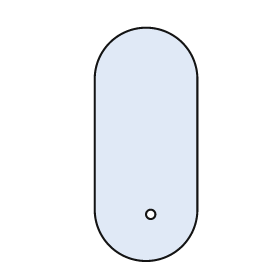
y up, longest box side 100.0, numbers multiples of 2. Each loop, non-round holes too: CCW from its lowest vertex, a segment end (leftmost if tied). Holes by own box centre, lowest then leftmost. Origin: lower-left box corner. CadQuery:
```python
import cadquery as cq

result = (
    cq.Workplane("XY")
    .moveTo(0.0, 22.0)
    .threePointArc((22.0, 0.0), (44.0, 22.0))
    .lineTo(44.0, 78.0)
    .threePointArc((22.0, 100.0), (0.0, 78.0))
    .close()
    .moveTo(24.0, 20.0)
    .circle(2.0)
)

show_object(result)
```